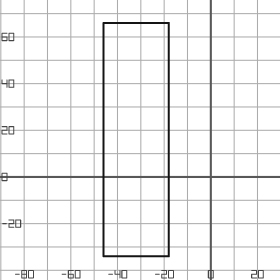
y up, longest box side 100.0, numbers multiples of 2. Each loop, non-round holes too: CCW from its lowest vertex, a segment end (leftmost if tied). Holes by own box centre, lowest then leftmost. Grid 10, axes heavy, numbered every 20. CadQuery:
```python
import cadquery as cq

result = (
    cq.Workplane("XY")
    .moveTo(-46.0, -34.0)
    .lineTo(-18.0, -34.0)
    .lineTo(-18.0, 66.0)
    .lineTo(-46.0, 66.0)
    .close()
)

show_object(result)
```